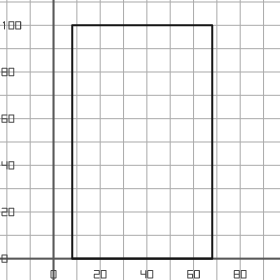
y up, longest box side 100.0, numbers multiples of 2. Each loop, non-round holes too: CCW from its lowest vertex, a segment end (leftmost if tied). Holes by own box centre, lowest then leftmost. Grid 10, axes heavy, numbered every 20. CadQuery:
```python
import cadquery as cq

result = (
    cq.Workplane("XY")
    .moveTo(8.0, 0.0)
    .lineTo(68.0, 0.0)
    .lineTo(68.0, 100.0)
    .lineTo(8.0, 100.0)
    .close()
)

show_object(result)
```